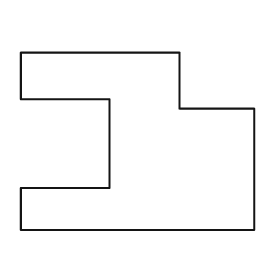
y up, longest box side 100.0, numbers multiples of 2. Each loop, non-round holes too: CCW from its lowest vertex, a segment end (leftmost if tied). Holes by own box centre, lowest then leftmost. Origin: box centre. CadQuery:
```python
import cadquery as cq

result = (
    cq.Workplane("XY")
    .moveTo(-50.0, -38.0)
    .lineTo(50.0, -38.0)
    .lineTo(50.0, 14.0)
    .lineTo(18.0, 14.0)
    .lineTo(18.0, 38.0)
    .lineTo(-50.0, 38.0)
    .lineTo(-50.0, 18.0)
    .lineTo(-12.0, 18.0)
    .lineTo(-12.0, -20.0)
    .lineTo(-50.0, -20.0)
    .close()
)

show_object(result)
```